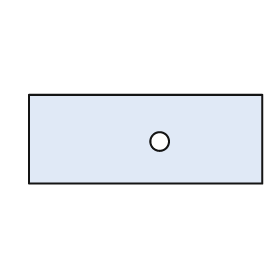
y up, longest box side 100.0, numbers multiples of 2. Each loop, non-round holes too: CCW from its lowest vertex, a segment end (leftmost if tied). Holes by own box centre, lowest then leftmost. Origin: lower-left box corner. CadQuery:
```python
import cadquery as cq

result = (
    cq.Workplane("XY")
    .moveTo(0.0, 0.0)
    .lineTo(100.0, 0.0)
    .lineTo(100.0, 38.0)
    .lineTo(0.0, 38.0)
    .close()
    .moveTo(56.0, 18.0)
    .circle(4.0)
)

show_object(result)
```